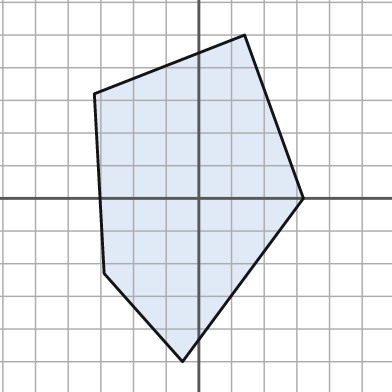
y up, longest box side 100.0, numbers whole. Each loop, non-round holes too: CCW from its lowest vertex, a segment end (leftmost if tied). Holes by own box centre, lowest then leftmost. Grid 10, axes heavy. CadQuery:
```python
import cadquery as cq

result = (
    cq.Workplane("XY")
    .moveTo(-5.0, -50.0)
    .lineTo(32.0, 0.0)
    .lineTo(14.0, 50.0)
    .lineTo(-32.0, 32.0)
    .lineTo(-29.0, -23.0)
    .close()
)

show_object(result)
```